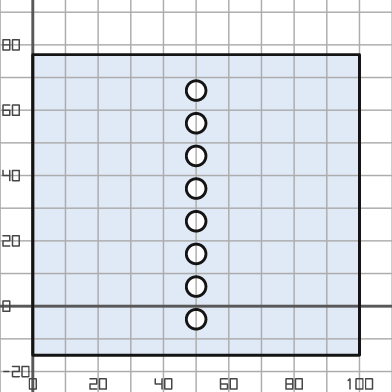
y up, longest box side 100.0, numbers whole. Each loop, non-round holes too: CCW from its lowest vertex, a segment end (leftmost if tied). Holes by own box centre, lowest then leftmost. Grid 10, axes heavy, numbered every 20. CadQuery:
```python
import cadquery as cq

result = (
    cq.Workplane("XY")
    .moveTo(0.0, -15.0)
    .lineTo(100.0, -15.0)
    .lineTo(100.0, 77.0)
    .lineTo(0.0, 77.0)
    .close()
    .moveTo(50.0, -4.0)
    .circle(3.0)
    .moveTo(50.0, 6.0)
    .circle(3.0)
    .moveTo(50.0, 16.0)
    .circle(3.0)
    .moveTo(50.0, 26.0)
    .circle(3.0)
    .moveTo(50.0, 36.0)
    .circle(3.0)
    .moveTo(50.0, 46.0)
    .circle(3.0)
    .moveTo(50.0, 56.0)
    .circle(3.0)
    .moveTo(50.0, 66.0)
    .circle(3.0)
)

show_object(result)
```